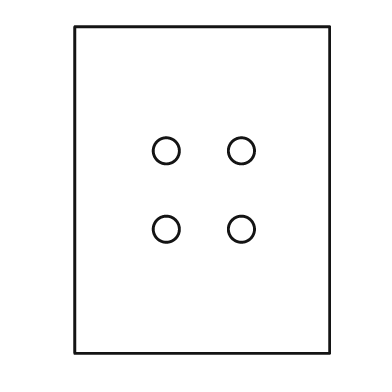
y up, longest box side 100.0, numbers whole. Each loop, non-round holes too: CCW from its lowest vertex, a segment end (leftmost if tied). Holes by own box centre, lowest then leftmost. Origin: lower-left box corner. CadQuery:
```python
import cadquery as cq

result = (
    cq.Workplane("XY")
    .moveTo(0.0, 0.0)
    .lineTo(78.0, 0.0)
    .lineTo(78.0, 100.0)
    .lineTo(0.0, 100.0)
    .close()
    .moveTo(28.0, 38.0)
    .circle(4.0)
    .moveTo(51.0, 38.0)
    .circle(4.0)
    .moveTo(28.0, 62.0)
    .circle(4.0)
    .moveTo(51.0, 62.0)
    .circle(4.0)
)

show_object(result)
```